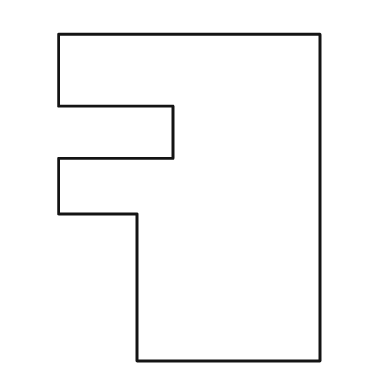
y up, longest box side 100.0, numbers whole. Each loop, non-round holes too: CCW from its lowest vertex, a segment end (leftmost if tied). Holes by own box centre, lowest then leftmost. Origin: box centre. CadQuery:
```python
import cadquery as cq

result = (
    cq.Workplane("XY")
    .moveTo(-16.0, -50.0)
    .lineTo(40.0, -50.0)
    .lineTo(40.0, 50.0)
    .lineTo(-40.0, 50.0)
    .lineTo(-40.0, 28.0)
    .lineTo(-5.0, 28.0)
    .lineTo(-5.0, 12.0)
    .lineTo(-40.0, 12.0)
    .lineTo(-40.0, -5.0)
    .lineTo(-16.0, -5.0)
    .close()
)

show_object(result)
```